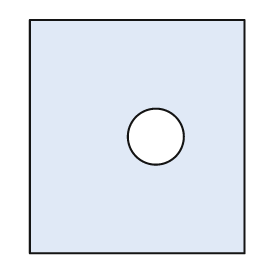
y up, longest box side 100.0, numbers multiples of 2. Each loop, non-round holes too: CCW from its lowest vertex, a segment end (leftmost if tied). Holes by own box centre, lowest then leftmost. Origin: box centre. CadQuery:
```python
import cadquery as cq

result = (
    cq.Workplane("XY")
    .moveTo(-46.0, -50.0)
    .lineTo(46.0, -50.0)
    .lineTo(46.0, 50.0)
    .lineTo(-46.0, 50.0)
    .close()
    .moveTo(8.0, 0.0)
    .circle(12.0)
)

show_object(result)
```